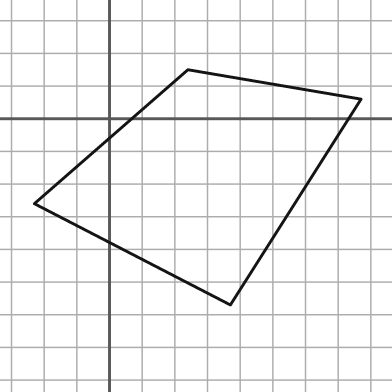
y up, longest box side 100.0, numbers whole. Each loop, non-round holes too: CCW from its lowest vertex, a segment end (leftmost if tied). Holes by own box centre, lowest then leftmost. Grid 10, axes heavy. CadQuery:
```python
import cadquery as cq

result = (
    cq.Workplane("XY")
    .moveTo(37.0, -57.0)
    .lineTo(77.0, 6.0)
    .lineTo(24.0, 15.0)
    .lineTo(-23.0, -26.0)
    .close()
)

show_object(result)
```